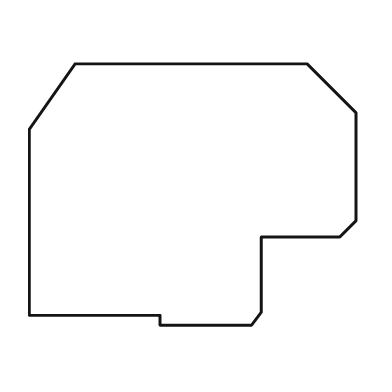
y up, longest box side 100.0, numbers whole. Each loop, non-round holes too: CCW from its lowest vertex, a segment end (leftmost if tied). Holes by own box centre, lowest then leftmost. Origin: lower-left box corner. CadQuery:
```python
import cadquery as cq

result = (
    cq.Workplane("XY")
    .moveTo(40.0, 0.0)
    .lineTo(68.0, 0.0)
    .lineTo(71.0, 4.0)
    .lineTo(71.0, 27.0)
    .lineTo(95.0, 27.0)
    .lineTo(100.0, 32.0)
    .lineTo(100.0, 65.0)
    .lineTo(85.0, 80.0)
    .lineTo(14.0, 80.0)
    .lineTo(0.0, 60.0)
    .lineTo(0.0, 3.0)
    .lineTo(40.0, 3.0)
    .close()
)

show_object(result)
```